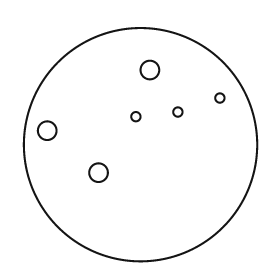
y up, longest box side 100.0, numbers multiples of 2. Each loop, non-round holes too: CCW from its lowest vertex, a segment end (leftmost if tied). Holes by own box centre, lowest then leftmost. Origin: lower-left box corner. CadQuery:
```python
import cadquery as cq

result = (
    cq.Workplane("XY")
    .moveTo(50.0, 50.0)
    .circle(50.0)
    .moveTo(32.0, 38.0)
    .circle(4.0)
    .moveTo(10.0, 56.0)
    .circle(4.0)
    .moveTo(48.0, 62.0)
    .circle(2.0)
    .moveTo(66.0, 64.0)
    .circle(2.0)
    .moveTo(84.0, 70.0)
    .circle(2.0)
    .moveTo(54.0, 82.0)
    .circle(4.0)
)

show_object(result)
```